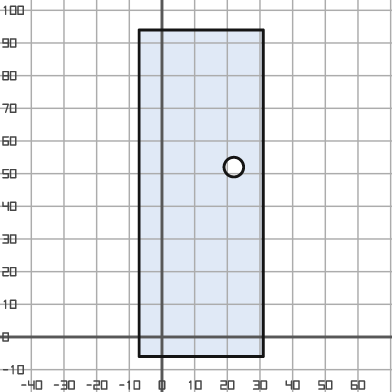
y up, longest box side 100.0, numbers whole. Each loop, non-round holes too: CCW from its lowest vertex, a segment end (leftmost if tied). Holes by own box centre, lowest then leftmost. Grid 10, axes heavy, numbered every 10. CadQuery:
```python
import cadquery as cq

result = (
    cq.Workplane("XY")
    .moveTo(-7.0, -6.0)
    .lineTo(31.0, -6.0)
    .lineTo(31.0, 94.0)
    .lineTo(-7.0, 94.0)
    .close()
    .moveTo(22.0, 52.0)
    .circle(3.0)
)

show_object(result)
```